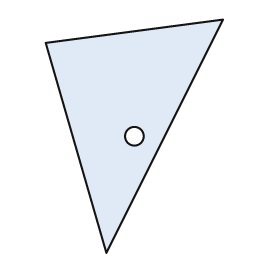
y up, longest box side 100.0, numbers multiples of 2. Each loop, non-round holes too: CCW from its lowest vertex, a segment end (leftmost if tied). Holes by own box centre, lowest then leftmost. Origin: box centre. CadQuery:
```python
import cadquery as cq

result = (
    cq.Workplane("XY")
    .moveTo(-12.0, -50.0)
    .lineTo(38.0, 50.0)
    .lineTo(-38.0, 40.0)
    .close()
    .moveTo(0.0, 0.0)
    .circle(4.0)
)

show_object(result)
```